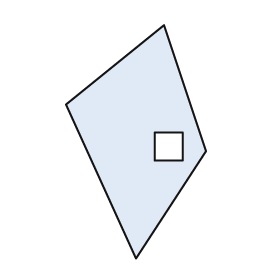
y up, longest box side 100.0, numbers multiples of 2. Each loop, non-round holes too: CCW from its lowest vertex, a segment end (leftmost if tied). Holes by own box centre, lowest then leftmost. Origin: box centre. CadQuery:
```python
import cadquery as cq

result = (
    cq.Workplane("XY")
    .moveTo(0.0, -50.0)
    .lineTo(30.0, -4.0)
    .lineTo(12.0, 50.0)
    .lineTo(-30.0, 16.0)
    .close()
    .moveTo(8.0, -8.0)
    .lineTo(20.0, -8.0)
    .lineTo(20.0, 4.0)
    .lineTo(8.0, 4.0)
    .close()
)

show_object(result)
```